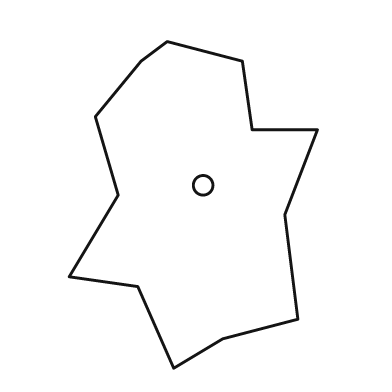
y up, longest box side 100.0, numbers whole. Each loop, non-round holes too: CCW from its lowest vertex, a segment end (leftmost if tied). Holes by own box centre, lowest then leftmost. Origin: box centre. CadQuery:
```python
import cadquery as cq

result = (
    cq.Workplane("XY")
    .moveTo(-6.0, -50.0)
    .lineTo(9.0, -41.0)
    .lineTo(32.0, -35.0)
    .lineTo(28.0, -3.0)
    .lineTo(38.0, 23.0)
    .lineTo(18.0, 23.0)
    .lineTo(15.0, 44.0)
    .lineTo(-8.0, 50.0)
    .lineTo(-16.0, 44.0)
    .lineTo(-30.0, 27.0)
    .lineTo(-23.0, 3.0)
    .lineTo(-38.0, -22.0)
    .lineTo(-17.0, -25.0)
    .close()
    .moveTo(3.0, 6.0)
    .circle(3.0)
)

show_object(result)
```